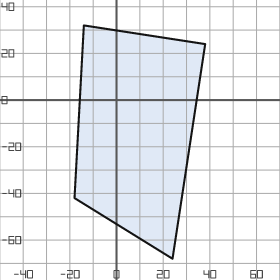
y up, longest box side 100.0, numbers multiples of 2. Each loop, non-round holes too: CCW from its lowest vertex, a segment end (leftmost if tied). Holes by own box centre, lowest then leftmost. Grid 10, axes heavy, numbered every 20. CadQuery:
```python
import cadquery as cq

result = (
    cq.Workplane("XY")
    .moveTo(24.0, -68.0)
    .lineTo(38.0, 24.0)
    .lineTo(-14.0, 32.0)
    .lineTo(-18.0, -42.0)
    .close()
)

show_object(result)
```